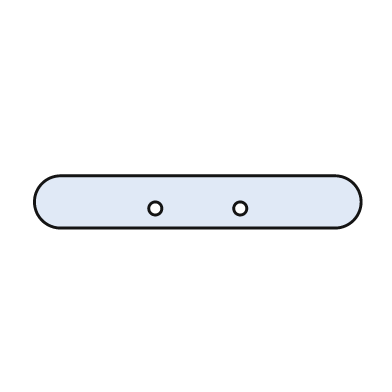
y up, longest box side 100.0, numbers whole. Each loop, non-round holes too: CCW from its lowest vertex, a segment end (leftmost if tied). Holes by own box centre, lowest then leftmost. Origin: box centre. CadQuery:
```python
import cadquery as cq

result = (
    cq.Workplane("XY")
    .moveTo(-42.0, -8.0)
    .lineTo(42.0, -8.0)
    .threePointArc((50.0, 0.0), (42.0, 8.0))
    .lineTo(-42.0, 8.0)
    .threePointArc((-50.0, 0.0), (-42.0, -8.0))
    .close()
    .moveTo(-13.0, -2.0)
    .circle(2.0)
    .moveTo(13.0, -2.0)
    .circle(2.0)
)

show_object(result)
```